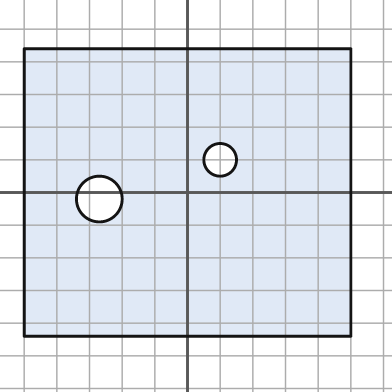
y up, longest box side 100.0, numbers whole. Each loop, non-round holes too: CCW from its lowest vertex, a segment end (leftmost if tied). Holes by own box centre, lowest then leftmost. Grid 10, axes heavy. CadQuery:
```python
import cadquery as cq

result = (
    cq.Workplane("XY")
    .moveTo(-50.0, -44.0)
    .lineTo(50.0, -44.0)
    .lineTo(50.0, 44.0)
    .lineTo(-50.0, 44.0)
    .close()
    .moveTo(-27.0, -2.0)
    .circle(7.0)
    .moveTo(10.0, 10.0)
    .circle(5.0)
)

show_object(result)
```